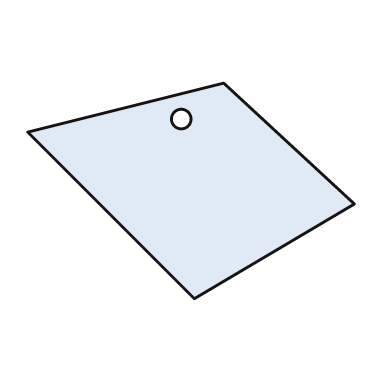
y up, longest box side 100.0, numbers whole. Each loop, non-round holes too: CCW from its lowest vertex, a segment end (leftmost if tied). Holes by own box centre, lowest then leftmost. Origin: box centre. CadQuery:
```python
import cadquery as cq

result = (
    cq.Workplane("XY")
    .moveTo(1.0, -33.0)
    .lineTo(50.0, -4.0)
    .lineTo(10.0, 33.0)
    .lineTo(-50.0, 18.0)
    .close()
    .moveTo(-3.0, 22.0)
    .circle(3.0)
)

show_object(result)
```